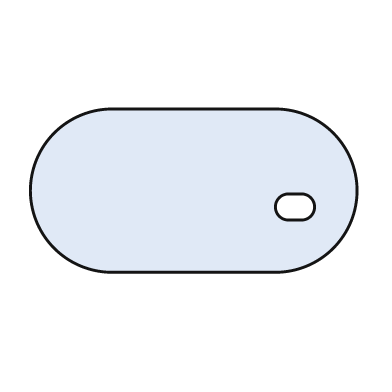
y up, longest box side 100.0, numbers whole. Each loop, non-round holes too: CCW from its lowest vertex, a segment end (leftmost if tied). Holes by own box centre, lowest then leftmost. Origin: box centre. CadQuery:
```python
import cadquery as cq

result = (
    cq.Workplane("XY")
    .moveTo(-25.0, -25.0)
    .lineTo(25.0, -25.0)
    .threePointArc((50.0, 0.0), (25.0, 25.0))
    .lineTo(-25.0, 25.0)
    .threePointArc((-50.0, 0.0), (-25.0, -25.0))
    .close()
    .moveTo(29.0, -9.0)
    .lineTo(33.0, -9.0)
    .threePointArc((37.0, -5.0), (33.0, -1.0))
    .lineTo(29.0, -1.0)
    .threePointArc((25.0, -5.0), (29.0, -9.0))
    .close()
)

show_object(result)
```